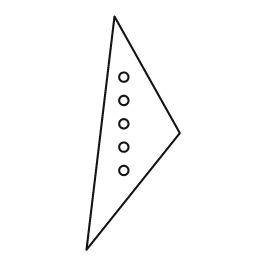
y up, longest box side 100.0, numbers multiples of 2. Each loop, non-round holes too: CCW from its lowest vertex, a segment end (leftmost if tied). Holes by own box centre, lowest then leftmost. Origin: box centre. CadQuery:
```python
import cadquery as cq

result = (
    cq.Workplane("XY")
    .moveTo(-20.0, -50.0)
    .lineTo(20.0, 0.0)
    .lineTo(-8.0, 50.0)
    .close()
    .moveTo(-4.0, -16.0)
    .circle(2.0)
    .moveTo(-4.0, -6.0)
    .circle(2.0)
    .moveTo(-4.0, 4.0)
    .circle(2.0)
    .moveTo(-4.0, 14.0)
    .circle(2.0)
    .moveTo(-4.0, 24.0)
    .circle(2.0)
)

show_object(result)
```